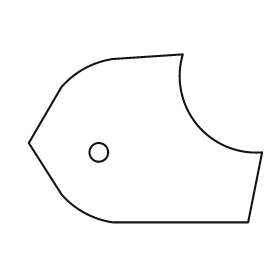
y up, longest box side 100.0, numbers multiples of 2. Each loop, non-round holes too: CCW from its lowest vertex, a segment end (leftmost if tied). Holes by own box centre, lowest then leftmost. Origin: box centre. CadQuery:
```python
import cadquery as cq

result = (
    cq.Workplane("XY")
    .moveTo(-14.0, -36.0)
    .lineTo(44.0, -36.0)
    .lineTo(50.0, -6.0)
    .threePointArc((22.0, 6.0), (16.0, 36.0))
    .lineTo(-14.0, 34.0)
    .threePointArc((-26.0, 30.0), (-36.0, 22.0))
    .lineTo(-50.0, -2.0)
    .lineTo(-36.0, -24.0)
    .threePointArc((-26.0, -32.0), (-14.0, -36.0))
    .close()
    .moveTo(-20.0, -6.0)
    .circle(4.0)
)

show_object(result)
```